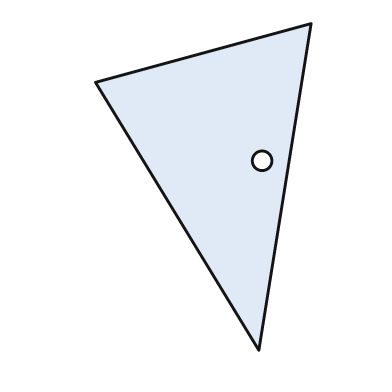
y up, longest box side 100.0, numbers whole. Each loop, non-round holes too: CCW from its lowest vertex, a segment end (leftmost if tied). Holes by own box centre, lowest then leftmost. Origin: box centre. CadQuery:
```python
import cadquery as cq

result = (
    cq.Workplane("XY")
    .moveTo(17.0, -50.0)
    .lineTo(33.0, 50.0)
    .lineTo(-33.0, 32.0)
    .close()
    .moveTo(18.0, 8.0)
    .circle(3.0)
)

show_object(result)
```